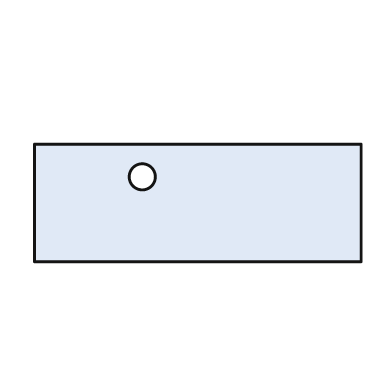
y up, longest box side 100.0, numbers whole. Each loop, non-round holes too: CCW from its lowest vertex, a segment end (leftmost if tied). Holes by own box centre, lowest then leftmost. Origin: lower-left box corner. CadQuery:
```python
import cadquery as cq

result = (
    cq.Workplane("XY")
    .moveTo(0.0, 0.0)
    .lineTo(100.0, 0.0)
    .lineTo(100.0, 36.0)
    .lineTo(0.0, 36.0)
    .close()
    .moveTo(33.0, 26.0)
    .circle(4.0)
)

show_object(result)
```